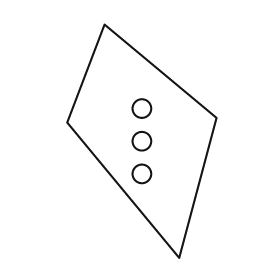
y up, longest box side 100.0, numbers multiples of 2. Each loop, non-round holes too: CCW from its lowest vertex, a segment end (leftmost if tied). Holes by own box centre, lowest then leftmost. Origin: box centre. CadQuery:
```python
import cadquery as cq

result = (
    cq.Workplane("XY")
    .moveTo(16.0, -50.0)
    .lineTo(32.0, 10.0)
    .lineTo(-16.0, 50.0)
    .lineTo(-32.0, 8.0)
    .close()
    .moveTo(0.0, -14.0)
    .circle(4.0)
    .moveTo(0.0, 0.0)
    .circle(4.0)
    .moveTo(0.0, 14.0)
    .circle(4.0)
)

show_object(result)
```